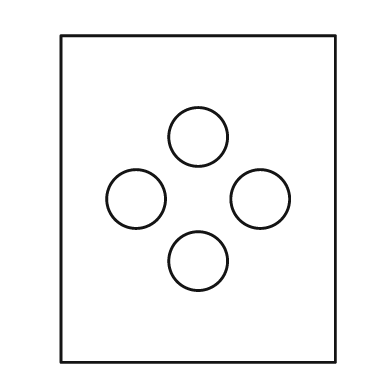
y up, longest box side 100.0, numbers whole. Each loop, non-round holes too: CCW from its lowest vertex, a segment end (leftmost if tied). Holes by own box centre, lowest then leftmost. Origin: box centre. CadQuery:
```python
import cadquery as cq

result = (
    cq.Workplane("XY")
    .moveTo(-42.0, -50.0)
    .lineTo(42.0, -50.0)
    .lineTo(42.0, 50.0)
    .lineTo(-42.0, 50.0)
    .close()
    .moveTo(0.0, -19.0)
    .circle(9.0)
    .moveTo(-19.0, 0.0)
    .circle(9.0)
    .moveTo(19.0, 0.0)
    .circle(9.0)
    .moveTo(0.0, 19.0)
    .circle(9.0)
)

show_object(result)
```